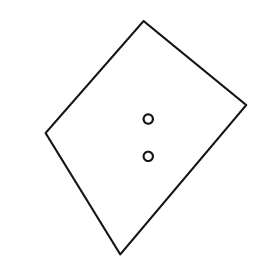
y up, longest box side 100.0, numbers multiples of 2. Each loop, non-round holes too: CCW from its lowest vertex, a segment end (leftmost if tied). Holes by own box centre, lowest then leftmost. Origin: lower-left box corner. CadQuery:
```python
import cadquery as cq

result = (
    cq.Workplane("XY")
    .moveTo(32.0, 0.0)
    .lineTo(86.0, 64.0)
    .lineTo(42.0, 100.0)
    .lineTo(0.0, 52.0)
    .close()
    .moveTo(44.0, 42.0)
    .circle(2.0)
    .moveTo(44.0, 58.0)
    .circle(2.0)
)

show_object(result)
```